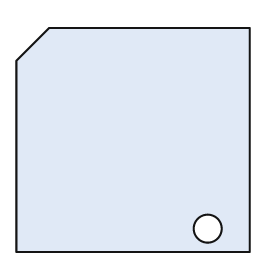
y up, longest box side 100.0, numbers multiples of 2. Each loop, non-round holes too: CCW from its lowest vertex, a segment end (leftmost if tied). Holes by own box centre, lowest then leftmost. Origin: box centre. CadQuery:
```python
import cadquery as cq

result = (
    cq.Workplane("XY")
    .moveTo(-50.0, -48.0)
    .lineTo(50.0, -48.0)
    .lineTo(50.0, 48.0)
    .lineTo(-36.0, 48.0)
    .lineTo(-50.0, 34.0)
    .close()
    .moveTo(32.0, -38.0)
    .circle(6.0)
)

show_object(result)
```